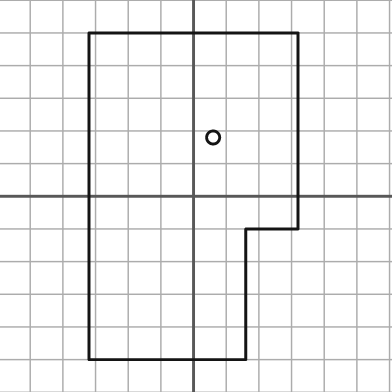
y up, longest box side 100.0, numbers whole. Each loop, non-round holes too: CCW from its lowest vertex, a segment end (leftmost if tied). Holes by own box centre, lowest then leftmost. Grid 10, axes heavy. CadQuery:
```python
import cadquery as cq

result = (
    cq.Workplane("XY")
    .moveTo(-32.0, -50.0)
    .lineTo(16.0, -50.0)
    .lineTo(16.0, -10.0)
    .lineTo(32.0, -10.0)
    .lineTo(32.0, 50.0)
    .lineTo(-32.0, 50.0)
    .close()
    .moveTo(6.0, 18.0)
    .circle(2.0)
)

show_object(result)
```